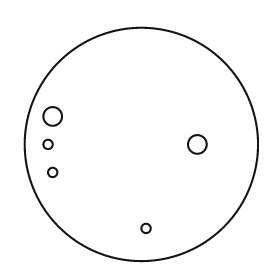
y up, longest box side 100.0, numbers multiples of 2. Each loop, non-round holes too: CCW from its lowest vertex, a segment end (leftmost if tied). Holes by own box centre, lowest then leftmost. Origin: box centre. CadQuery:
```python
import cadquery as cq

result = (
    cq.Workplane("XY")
    .moveTo(0.0, 0.0)
    .circle(50.0)
    .moveTo(2.0, -36.0)
    .circle(2.0)
    .moveTo(-38.0, -12.0)
    .circle(2.0)
    .moveTo(-40.0, 0.0)
    .circle(2.0)
    .moveTo(24.0, 0.0)
    .circle(4.0)
    .moveTo(-38.0, 12.0)
    .circle(4.0)
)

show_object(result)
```